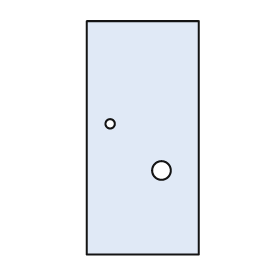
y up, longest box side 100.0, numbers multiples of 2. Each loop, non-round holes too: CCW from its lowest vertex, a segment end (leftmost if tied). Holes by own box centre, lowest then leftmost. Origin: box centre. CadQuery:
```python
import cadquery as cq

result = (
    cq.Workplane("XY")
    .moveTo(-24.0, -50.0)
    .lineTo(24.0, -50.0)
    .lineTo(24.0, 50.0)
    .lineTo(-24.0, 50.0)
    .close()
    .moveTo(8.0, -14.0)
    .circle(4.0)
    .moveTo(-14.0, 6.0)
    .circle(2.0)
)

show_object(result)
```